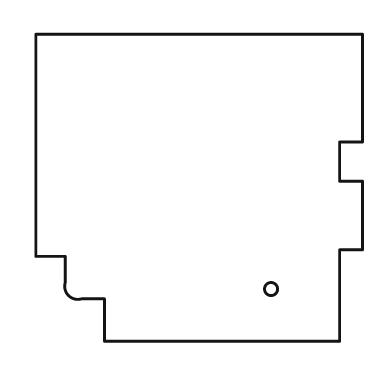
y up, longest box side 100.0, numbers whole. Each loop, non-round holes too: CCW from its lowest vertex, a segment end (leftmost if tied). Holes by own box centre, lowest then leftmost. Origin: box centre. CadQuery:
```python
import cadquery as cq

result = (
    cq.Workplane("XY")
    .moveTo(-29.0, -47.0)
    .lineTo(43.0, -47.0)
    .lineTo(43.0, -19.0)
    .lineTo(50.0, -19.0)
    .lineTo(50.0, 2.0)
    .lineTo(43.0, 2.0)
    .lineTo(43.0, 14.0)
    .lineTo(50.0, 14.0)
    .lineTo(50.0, 47.0)
    .lineTo(-50.0, 47.0)
    .lineTo(-50.0, -21.0)
    .lineTo(-41.0, -21.0)
    .lineTo(-41.0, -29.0)
    .threePointArc((-40.0, -33.0), (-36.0, -34.0))
    .lineTo(-29.0, -34.0)
    .close()
    .moveTo(22.0, -31.0)
    .circle(2.0)
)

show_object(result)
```